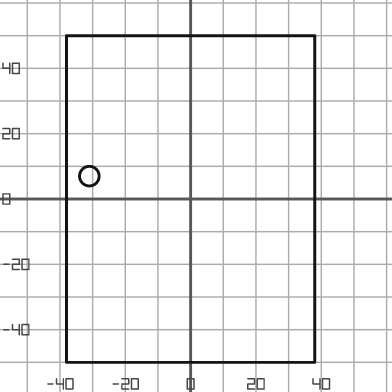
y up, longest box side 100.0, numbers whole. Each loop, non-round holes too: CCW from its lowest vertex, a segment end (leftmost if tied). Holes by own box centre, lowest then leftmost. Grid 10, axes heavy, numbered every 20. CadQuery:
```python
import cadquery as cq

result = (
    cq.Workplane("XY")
    .moveTo(-38.0, -50.0)
    .lineTo(38.0, -50.0)
    .lineTo(38.0, 50.0)
    .lineTo(-38.0, 50.0)
    .close()
    .moveTo(-31.0, 7.0)
    .circle(3.0)
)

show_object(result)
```